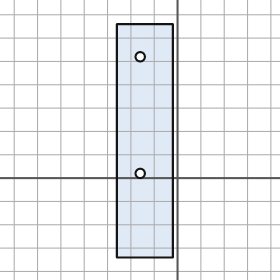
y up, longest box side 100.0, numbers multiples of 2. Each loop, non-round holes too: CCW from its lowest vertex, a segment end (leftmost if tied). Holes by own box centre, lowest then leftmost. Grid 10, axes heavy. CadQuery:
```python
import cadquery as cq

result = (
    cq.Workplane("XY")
    .moveTo(-26.0, -34.0)
    .lineTo(-2.0, -34.0)
    .lineTo(-2.0, 66.0)
    .lineTo(-26.0, 66.0)
    .close()
    .moveTo(-16.0, 2.0)
    .circle(2.0)
    .moveTo(-16.0, 52.0)
    .circle(2.0)
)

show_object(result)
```